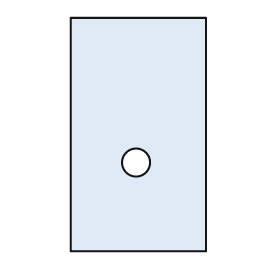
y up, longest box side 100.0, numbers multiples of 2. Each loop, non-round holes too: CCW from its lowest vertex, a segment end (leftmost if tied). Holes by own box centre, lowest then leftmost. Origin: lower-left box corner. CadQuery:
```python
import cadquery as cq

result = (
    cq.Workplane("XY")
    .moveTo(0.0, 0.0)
    .lineTo(58.0, 0.0)
    .lineTo(58.0, 100.0)
    .lineTo(0.0, 100.0)
    .close()
    .moveTo(28.0, 38.0)
    .circle(6.0)
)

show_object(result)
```